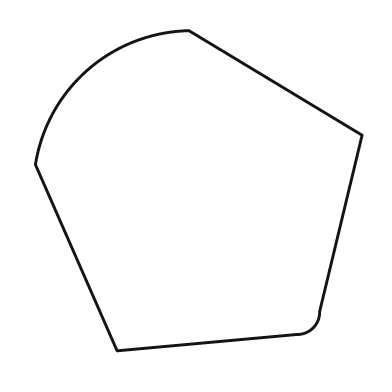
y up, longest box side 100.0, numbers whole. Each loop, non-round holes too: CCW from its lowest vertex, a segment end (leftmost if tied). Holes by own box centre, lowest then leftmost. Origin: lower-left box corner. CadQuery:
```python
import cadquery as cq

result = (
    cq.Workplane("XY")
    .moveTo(25.0, 0.0)
    .lineTo(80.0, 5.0)
    .threePointArc((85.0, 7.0), (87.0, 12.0))
    .lineTo(100.0, 66.0)
    .lineTo(47.0, 98.0)
    .threePointArc((16.0, 86.0), (0.0, 57.0))
    .close()
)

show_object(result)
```